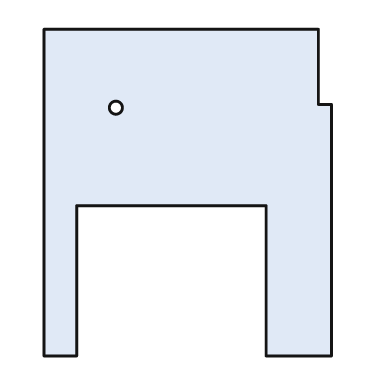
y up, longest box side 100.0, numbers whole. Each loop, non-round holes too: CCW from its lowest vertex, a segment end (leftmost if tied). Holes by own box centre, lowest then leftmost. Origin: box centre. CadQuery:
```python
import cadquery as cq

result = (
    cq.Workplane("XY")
    .moveTo(-44.0, -50.0)
    .lineTo(-34.0, -50.0)
    .lineTo(-34.0, -4.0)
    .lineTo(24.0, -4.0)
    .lineTo(24.0, -50.0)
    .lineTo(44.0, -50.0)
    .lineTo(44.0, 27.0)
    .lineTo(40.0, 27.0)
    .lineTo(40.0, 50.0)
    .lineTo(-44.0, 50.0)
    .close()
    .moveTo(-22.0, 26.0)
    .circle(2.0)
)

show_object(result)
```